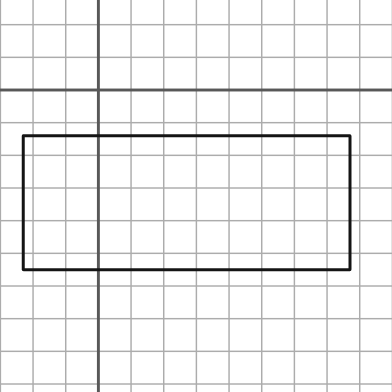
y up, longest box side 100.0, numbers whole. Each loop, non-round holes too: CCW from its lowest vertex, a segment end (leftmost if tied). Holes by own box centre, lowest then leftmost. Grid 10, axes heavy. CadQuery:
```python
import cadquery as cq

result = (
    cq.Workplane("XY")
    .moveTo(-23.0, -55.0)
    .lineTo(77.0, -55.0)
    .lineTo(77.0, -14.0)
    .lineTo(-23.0, -14.0)
    .close()
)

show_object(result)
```